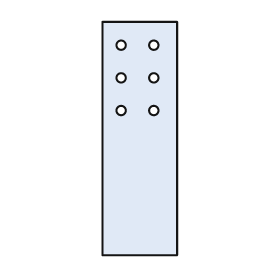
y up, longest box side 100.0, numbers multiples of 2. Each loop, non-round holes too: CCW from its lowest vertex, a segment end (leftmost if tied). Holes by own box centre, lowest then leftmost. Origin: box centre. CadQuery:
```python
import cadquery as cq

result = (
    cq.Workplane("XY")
    .moveTo(-16.0, -50.0)
    .lineTo(16.0, -50.0)
    .lineTo(16.0, 50.0)
    .lineTo(-16.0, 50.0)
    .close()
    .moveTo(-8.0, 12.0)
    .circle(2.0)
    .moveTo(6.0, 12.0)
    .circle(2.0)
    .moveTo(-8.0, 26.0)
    .circle(2.0)
    .moveTo(6.0, 26.0)
    .circle(2.0)
    .moveTo(-8.0, 40.0)
    .circle(2.0)
    .moveTo(6.0, 40.0)
    .circle(2.0)
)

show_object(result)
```